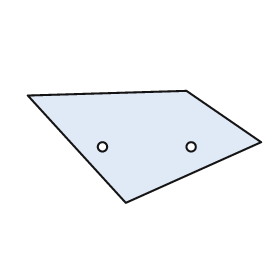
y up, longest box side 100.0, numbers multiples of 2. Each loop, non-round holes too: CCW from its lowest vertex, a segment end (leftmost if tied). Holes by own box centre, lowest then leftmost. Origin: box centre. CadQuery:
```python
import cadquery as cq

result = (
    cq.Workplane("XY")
    .moveTo(-8.0, -24.0)
    .lineTo(50.0, 2.0)
    .lineTo(18.0, 24.0)
    .lineTo(-50.0, 22.0)
    .close()
    .moveTo(-18.0, 0.0)
    .circle(2.0)
    .moveTo(20.0, 0.0)
    .circle(2.0)
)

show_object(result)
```